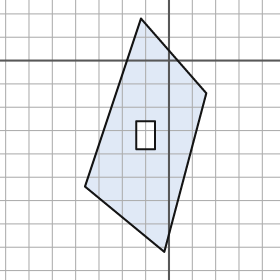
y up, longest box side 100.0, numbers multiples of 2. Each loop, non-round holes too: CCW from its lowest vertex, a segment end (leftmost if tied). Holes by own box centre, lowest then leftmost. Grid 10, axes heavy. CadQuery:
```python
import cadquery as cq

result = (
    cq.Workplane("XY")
    .moveTo(-2.0, -82.0)
    .lineTo(16.0, -14.0)
    .lineTo(-12.0, 18.0)
    .lineTo(-36.0, -54.0)
    .close()
    .moveTo(-14.0, -38.0)
    .lineTo(-6.0, -38.0)
    .lineTo(-6.0, -26.0)
    .lineTo(-14.0, -26.0)
    .close()
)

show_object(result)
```